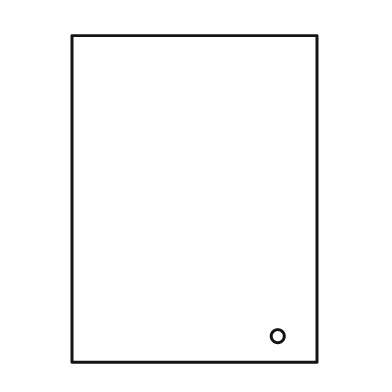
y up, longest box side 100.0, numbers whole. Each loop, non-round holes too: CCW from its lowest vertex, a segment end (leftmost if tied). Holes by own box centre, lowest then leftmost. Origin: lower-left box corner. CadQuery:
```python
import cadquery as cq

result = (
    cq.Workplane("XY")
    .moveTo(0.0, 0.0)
    .lineTo(75.0, 0.0)
    .lineTo(75.0, 100.0)
    .lineTo(0.0, 100.0)
    .close()
    .moveTo(63.0, 8.0)
    .circle(2.0)
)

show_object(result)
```